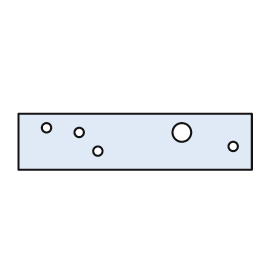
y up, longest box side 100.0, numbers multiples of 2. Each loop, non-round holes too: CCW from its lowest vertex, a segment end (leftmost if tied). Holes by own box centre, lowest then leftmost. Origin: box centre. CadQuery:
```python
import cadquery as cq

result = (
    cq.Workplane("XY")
    .moveTo(-50.0, -12.0)
    .lineTo(50.0, -12.0)
    .lineTo(50.0, 12.0)
    .lineTo(-50.0, 12.0)
    .close()
    .moveTo(-16.0, -4.0)
    .circle(2.0)
    .moveTo(42.0, -2.0)
    .circle(2.0)
    .moveTo(-24.0, 4.0)
    .circle(2.0)
    .moveTo(20.0, 4.0)
    .circle(4.0)
    .moveTo(-38.0, 6.0)
    .circle(2.0)
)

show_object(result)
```